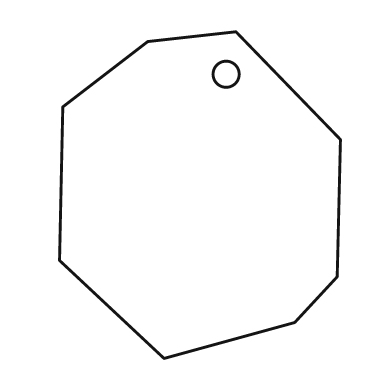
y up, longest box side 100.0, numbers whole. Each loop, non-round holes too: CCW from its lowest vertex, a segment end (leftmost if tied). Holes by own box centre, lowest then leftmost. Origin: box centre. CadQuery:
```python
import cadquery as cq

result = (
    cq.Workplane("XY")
    .moveTo(-11.0, -50.0)
    .lineTo(29.0, -39.0)
    .lineTo(42.0, -25.0)
    .lineTo(43.0, 17.0)
    .lineTo(11.0, 50.0)
    .lineTo(-16.0, 47.0)
    .lineTo(-42.0, 27.0)
    .lineTo(-43.0, -20.0)
    .close()
    .moveTo(8.0, 37.0)
    .circle(4.0)
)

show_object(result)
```